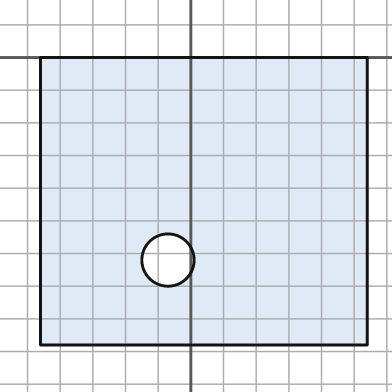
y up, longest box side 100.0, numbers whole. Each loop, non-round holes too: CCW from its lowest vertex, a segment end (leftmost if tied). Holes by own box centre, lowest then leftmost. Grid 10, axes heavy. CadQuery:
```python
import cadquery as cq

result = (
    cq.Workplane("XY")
    .moveTo(-46.0, -88.0)
    .lineTo(54.0, -88.0)
    .lineTo(54.0, 0.0)
    .lineTo(-46.0, 0.0)
    .close()
    .moveTo(-7.0, -62.0)
    .circle(8.0)
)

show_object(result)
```